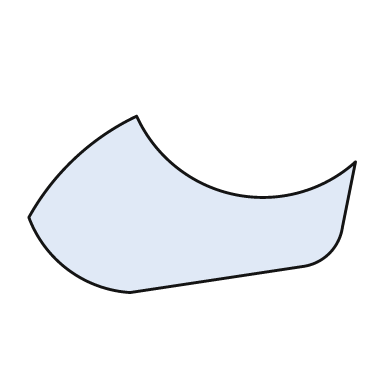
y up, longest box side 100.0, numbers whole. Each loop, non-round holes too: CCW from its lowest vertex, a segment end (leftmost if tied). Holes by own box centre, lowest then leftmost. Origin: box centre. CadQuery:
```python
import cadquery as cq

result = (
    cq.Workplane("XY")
    .moveTo(-19.0, -27.0)
    .lineTo(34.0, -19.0)
    .threePointArc((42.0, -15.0), (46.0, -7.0))
    .lineTo(50.0, 13.0)
    .threePointArc((13.0, 3.0), (-17.0, 27.0))
    .threePointArc((-36.0, 14.0), (-50.0, -4.0))
    .threePointArc((-38.0, -20.0), (-19.0, -27.0))
    .close()
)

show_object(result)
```